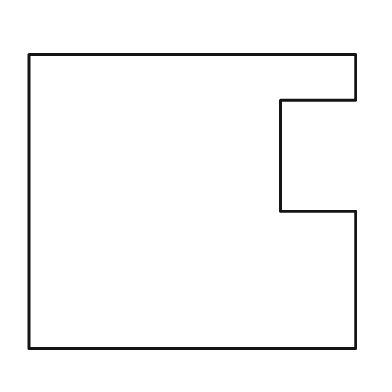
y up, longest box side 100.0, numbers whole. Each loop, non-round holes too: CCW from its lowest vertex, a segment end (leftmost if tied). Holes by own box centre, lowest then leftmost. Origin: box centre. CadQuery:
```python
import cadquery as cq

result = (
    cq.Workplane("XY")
    .moveTo(-50.0, -45.0)
    .lineTo(50.0, -45.0)
    .lineTo(50.0, -3.0)
    .lineTo(27.0, -3.0)
    .lineTo(27.0, 31.0)
    .lineTo(50.0, 31.0)
    .lineTo(50.0, 45.0)
    .lineTo(-50.0, 45.0)
    .close()
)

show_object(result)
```